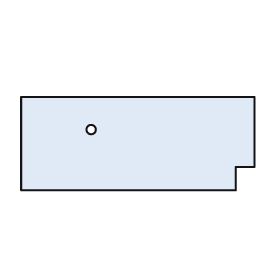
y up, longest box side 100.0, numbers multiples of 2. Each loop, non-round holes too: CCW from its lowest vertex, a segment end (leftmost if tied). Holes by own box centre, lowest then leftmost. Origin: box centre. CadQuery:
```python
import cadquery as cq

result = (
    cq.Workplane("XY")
    .moveTo(-50.0, -20.0)
    .lineTo(42.0, -20.0)
    .lineTo(42.0, -10.0)
    .lineTo(50.0, -10.0)
    .lineTo(50.0, 20.0)
    .lineTo(-50.0, 20.0)
    .close()
    .moveTo(-20.0, 6.0)
    .circle(2.0)
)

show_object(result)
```